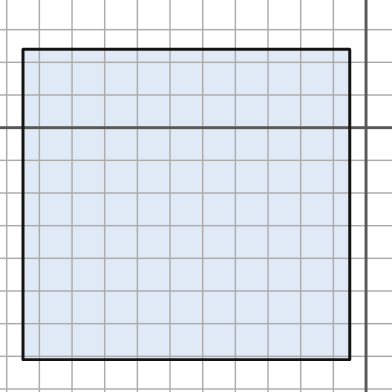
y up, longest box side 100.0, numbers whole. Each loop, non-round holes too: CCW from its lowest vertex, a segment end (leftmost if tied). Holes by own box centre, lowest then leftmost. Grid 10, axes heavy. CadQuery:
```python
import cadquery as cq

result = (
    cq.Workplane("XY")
    .moveTo(-105.0, -71.0)
    .lineTo(-5.0, -71.0)
    .lineTo(-5.0, 24.0)
    .lineTo(-105.0, 24.0)
    .close()
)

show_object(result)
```